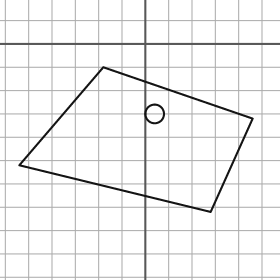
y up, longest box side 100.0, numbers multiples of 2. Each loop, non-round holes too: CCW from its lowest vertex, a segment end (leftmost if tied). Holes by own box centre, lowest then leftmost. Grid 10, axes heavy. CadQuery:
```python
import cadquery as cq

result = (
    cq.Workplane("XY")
    .moveTo(28.0, -72.0)
    .lineTo(46.0, -32.0)
    .lineTo(-18.0, -10.0)
    .lineTo(-54.0, -52.0)
    .close()
    .moveTo(4.0, -30.0)
    .circle(4.0)
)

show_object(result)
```